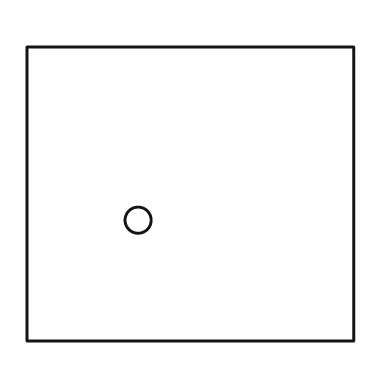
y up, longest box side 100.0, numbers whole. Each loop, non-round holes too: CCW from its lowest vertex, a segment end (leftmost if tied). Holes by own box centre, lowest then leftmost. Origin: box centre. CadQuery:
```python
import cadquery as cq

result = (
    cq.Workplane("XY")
    .moveTo(-50.0, -45.0)
    .lineTo(50.0, -45.0)
    .lineTo(50.0, 45.0)
    .lineTo(-50.0, 45.0)
    .close()
    .moveTo(-16.0, -8.0)
    .circle(4.0)
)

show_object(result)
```